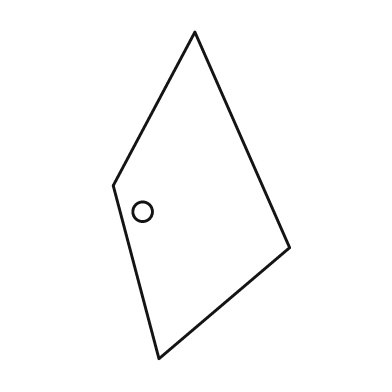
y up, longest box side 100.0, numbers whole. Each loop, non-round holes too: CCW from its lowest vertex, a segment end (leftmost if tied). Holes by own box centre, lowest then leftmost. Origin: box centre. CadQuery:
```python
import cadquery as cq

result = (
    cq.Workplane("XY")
    .moveTo(-13.0, -50.0)
    .lineTo(27.0, -16.0)
    .lineTo(-2.0, 50.0)
    .lineTo(-27.0, 3.0)
    .close()
    .moveTo(-18.0, -5.0)
    .circle(3.0)
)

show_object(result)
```